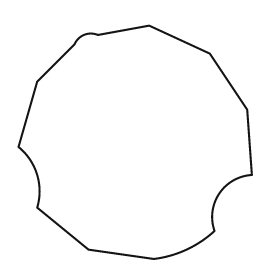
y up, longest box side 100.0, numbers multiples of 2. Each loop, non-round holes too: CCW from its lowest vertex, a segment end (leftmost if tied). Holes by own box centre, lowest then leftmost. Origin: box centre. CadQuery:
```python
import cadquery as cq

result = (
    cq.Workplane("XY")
    .moveTo(8.0, -50.0)
    .threePointArc((22.0, -46.0), (34.0, -38.0))
    .threePointArc((36.0, -22.0), (50.0, -14.0))
    .lineTo(48.0, 14.0)
    .lineTo(32.0, 38.0)
    .lineTo(6.0, 50.0)
    .lineTo(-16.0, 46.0)
    .threePointArc((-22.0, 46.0), (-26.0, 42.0))
    .lineTo(-42.0, 26.0)
    .lineTo(-50.0, -2.0)
    .threePointArc((-42.0, -14.0), (-42.0, -28.0))
    .lineTo(-20.0, -46.0)
    .close()
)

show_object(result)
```